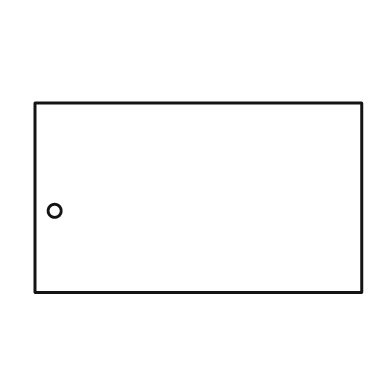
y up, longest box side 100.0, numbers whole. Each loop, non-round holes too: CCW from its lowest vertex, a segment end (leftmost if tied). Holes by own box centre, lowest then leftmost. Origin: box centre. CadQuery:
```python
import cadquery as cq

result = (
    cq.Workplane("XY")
    .moveTo(-50.0, -29.0)
    .lineTo(50.0, -29.0)
    .lineTo(50.0, 29.0)
    .lineTo(-50.0, 29.0)
    .close()
    .moveTo(-44.0, -4.0)
    .circle(2.0)
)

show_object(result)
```